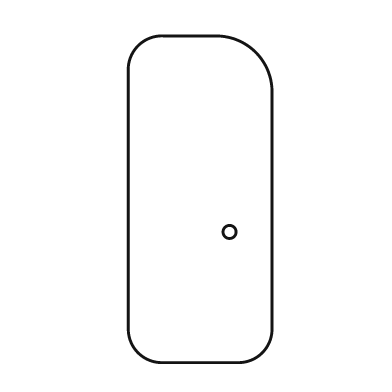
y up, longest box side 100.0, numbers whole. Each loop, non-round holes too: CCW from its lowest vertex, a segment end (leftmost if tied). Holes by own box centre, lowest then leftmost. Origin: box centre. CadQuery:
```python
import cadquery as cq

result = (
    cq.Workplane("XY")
    .moveTo(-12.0, -50.0)
    .lineTo(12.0, -50.0)
    .threePointArc((19.0, -47.0), (22.0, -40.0))
    .lineTo(22.0, 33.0)
    .threePointArc((17.0, 45.0), (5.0, 50.0))
    .lineTo(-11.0, 50.0)
    .threePointArc((-19.0, 47.0), (-22.0, 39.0))
    .lineTo(-22.0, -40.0)
    .threePointArc((-19.0, -47.0), (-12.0, -50.0))
    .close()
    .moveTo(9.0, -10.0)
    .circle(2.0)
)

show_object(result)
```